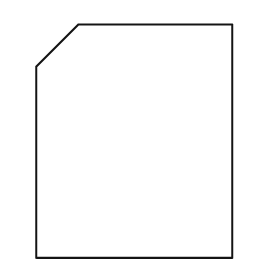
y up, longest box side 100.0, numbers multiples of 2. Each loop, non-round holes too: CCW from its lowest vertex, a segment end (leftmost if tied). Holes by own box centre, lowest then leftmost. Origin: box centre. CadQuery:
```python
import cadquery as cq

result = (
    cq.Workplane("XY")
    .moveTo(-42.0, -50.0)
    .lineTo(42.0, -50.0)
    .lineTo(42.0, 50.0)
    .lineTo(-24.0, 50.0)
    .lineTo(-42.0, 32.0)
    .close()
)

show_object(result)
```